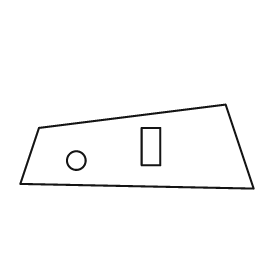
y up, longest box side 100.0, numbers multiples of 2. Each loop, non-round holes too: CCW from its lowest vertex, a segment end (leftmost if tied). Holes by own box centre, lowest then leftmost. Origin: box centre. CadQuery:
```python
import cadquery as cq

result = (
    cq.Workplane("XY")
    .moveTo(50.0, -18.0)
    .lineTo(38.0, 18.0)
    .lineTo(-42.0, 8.0)
    .lineTo(-50.0, -16.0)
    .close()
    .moveTo(-26.0, -6.0)
    .circle(4.0)
    .moveTo(2.0, -8.0)
    .lineTo(10.0, -8.0)
    .lineTo(10.0, 8.0)
    .lineTo(2.0, 8.0)
    .close()
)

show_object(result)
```